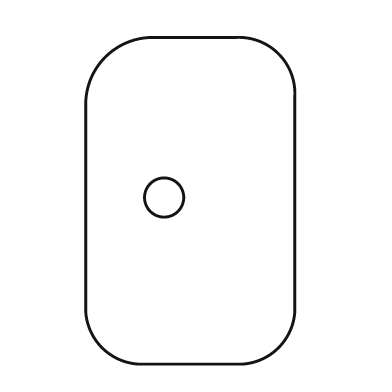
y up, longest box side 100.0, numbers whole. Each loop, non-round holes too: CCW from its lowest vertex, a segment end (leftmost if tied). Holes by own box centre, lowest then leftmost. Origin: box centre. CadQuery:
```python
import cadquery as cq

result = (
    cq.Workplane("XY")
    .moveTo(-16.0, -50.0)
    .lineTo(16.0, -50.0)
    .threePointArc((27.0, -45.0), (32.0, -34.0))
    .lineTo(32.0, 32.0)
    .threePointArc((27.0, 45.0), (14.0, 50.0))
    .lineTo(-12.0, 50.0)
    .threePointArc((-26.0, 44.0), (-32.0, 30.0))
    .lineTo(-32.0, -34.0)
    .threePointArc((-27.0, -45.0), (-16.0, -50.0))
    .close()
    .moveTo(-8.0, 1.0)
    .circle(6.0)
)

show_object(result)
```